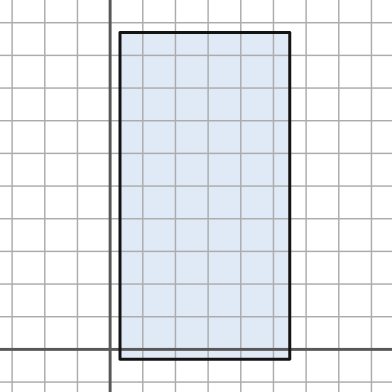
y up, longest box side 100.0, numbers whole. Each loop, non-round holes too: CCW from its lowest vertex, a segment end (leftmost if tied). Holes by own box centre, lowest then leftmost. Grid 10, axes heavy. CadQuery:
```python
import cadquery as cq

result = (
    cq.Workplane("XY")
    .moveTo(3.0, -3.0)
    .lineTo(55.0, -3.0)
    .lineTo(55.0, 97.0)
    .lineTo(3.0, 97.0)
    .close()
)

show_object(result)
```